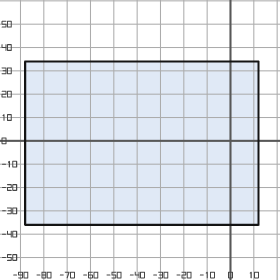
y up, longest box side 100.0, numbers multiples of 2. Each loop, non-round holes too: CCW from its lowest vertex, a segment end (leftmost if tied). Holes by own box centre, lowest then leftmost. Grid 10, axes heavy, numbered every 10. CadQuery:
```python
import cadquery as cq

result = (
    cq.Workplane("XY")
    .moveTo(-88.0, -36.0)
    .lineTo(12.0, -36.0)
    .lineTo(12.0, 34.0)
    .lineTo(-88.0, 34.0)
    .close()
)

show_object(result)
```